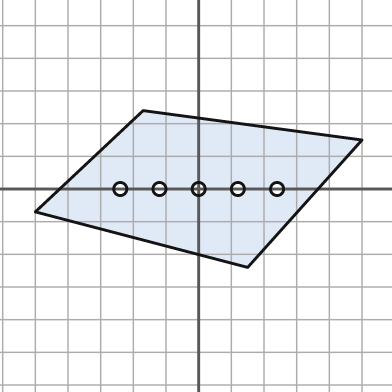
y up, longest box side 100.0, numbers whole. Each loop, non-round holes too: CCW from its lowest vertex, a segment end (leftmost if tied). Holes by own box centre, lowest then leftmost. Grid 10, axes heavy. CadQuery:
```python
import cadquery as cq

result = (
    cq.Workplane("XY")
    .moveTo(15.0, -24.0)
    .lineTo(50.0, 15.0)
    .lineTo(-17.0, 24.0)
    .lineTo(-50.0, -7.0)
    .close()
    .moveTo(-24.0, 0.0)
    .circle(2.0)
    .moveTo(-12.0, 0.0)
    .circle(2.0)
    .moveTo(0.0, 0.0)
    .circle(2.0)
    .moveTo(12.0, 0.0)
    .circle(2.0)
    .moveTo(24.0, 0.0)
    .circle(2.0)
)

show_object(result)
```